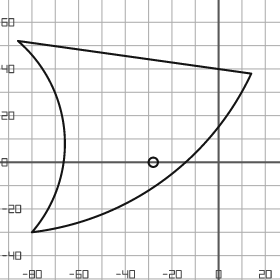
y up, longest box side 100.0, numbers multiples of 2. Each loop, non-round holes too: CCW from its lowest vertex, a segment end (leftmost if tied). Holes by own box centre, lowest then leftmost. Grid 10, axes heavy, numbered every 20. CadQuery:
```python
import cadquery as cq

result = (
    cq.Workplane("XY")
    .moveTo(-80.0, -30.0)
    .threePointArc((-24.0, -8.0), (14.0, 38.0))
    .lineTo(-86.0, 52.0)
    .threePointArc((-66.0, 12.0), (-80.0, -30.0))
    .close()
    .moveTo(-28.0, 0.0)
    .circle(2.0)
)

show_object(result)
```